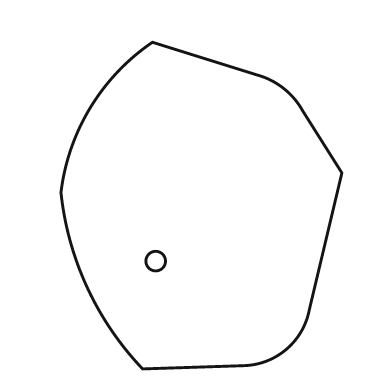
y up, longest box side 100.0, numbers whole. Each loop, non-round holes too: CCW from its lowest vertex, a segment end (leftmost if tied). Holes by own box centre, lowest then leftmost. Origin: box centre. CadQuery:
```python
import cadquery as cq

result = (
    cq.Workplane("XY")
    .moveTo(-18.0, -50.0)
    .lineTo(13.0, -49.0)
    .threePointArc((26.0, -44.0), (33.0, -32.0))
    .lineTo(43.0, 10.0)
    .lineTo(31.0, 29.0)
    .threePointArc((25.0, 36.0), (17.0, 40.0))
    .lineTo(-15.0, 50.0)
    .threePointArc((-34.0, 30.0), (-43.0, 4.0))
    .threePointArc((-35.0, -25.0), (-18.0, -50.0))
    .close()
    .moveTo(-14.0, -17.0)
    .circle(3.0)
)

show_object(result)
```